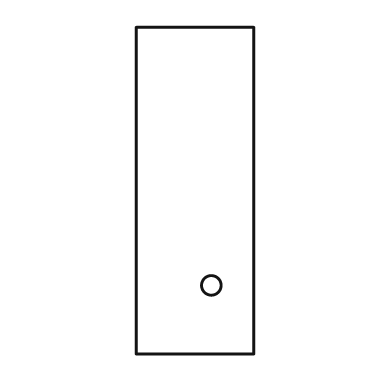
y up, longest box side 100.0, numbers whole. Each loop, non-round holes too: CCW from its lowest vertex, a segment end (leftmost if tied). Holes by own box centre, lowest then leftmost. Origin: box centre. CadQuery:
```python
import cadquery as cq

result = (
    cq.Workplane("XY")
    .moveTo(-18.0, -50.0)
    .lineTo(18.0, -50.0)
    .lineTo(18.0, 50.0)
    .lineTo(-18.0, 50.0)
    .close()
    .moveTo(5.0, -29.0)
    .circle(3.0)
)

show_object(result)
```